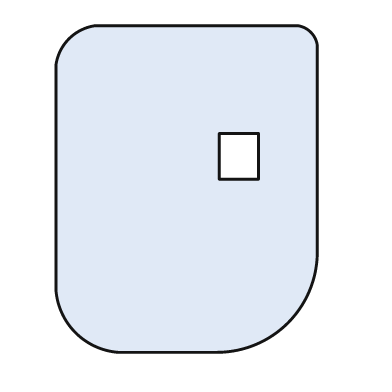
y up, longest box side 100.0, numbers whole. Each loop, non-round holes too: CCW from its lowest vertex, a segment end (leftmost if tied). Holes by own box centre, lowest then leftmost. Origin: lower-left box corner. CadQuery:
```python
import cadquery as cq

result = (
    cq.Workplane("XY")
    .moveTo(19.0, 0.0)
    .lineTo(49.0, 0.0)
    .threePointArc((71.0, 9.0), (80.0, 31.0))
    .lineTo(80.0, 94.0)
    .threePointArc((78.0, 98.0), (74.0, 100.0))
    .lineTo(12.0, 100.0)
    .threePointArc((4.0, 96.0), (0.0, 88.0))
    .lineTo(0.0, 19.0)
    .threePointArc((6.0, 6.0), (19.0, 0.0))
    .close()
    .moveTo(50.0, 53.0)
    .lineTo(62.0, 53.0)
    .lineTo(62.0, 67.0)
    .lineTo(50.0, 67.0)
    .close()
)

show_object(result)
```